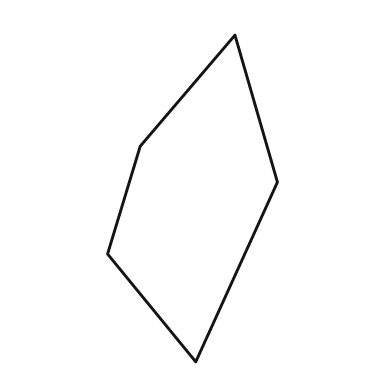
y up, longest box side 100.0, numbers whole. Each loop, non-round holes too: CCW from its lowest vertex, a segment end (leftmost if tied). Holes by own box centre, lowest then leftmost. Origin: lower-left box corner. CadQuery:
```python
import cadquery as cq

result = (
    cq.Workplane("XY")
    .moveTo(27.0, 0.0)
    .lineTo(52.0, 55.0)
    .lineTo(39.0, 100.0)
    .lineTo(10.0, 66.0)
    .lineTo(0.0, 33.0)
    .close()
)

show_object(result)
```